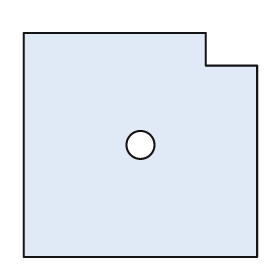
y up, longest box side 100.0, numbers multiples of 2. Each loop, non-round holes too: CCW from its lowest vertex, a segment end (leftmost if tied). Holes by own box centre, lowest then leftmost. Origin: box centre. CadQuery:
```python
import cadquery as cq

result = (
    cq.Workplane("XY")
    .moveTo(-50.0, -48.0)
    .lineTo(50.0, -48.0)
    .lineTo(50.0, 34.0)
    .lineTo(28.0, 34.0)
    .lineTo(28.0, 48.0)
    .lineTo(-50.0, 48.0)
    .close()
    .moveTo(0.0, 0.0)
    .circle(6.0)
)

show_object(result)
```